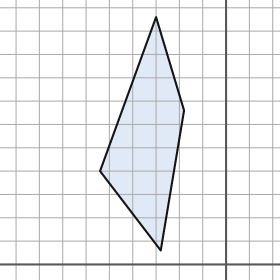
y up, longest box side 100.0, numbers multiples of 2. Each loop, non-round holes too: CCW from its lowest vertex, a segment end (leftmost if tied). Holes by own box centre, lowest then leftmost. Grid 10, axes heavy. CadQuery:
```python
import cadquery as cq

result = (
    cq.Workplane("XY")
    .moveTo(-28.0, 6.0)
    .lineTo(-18.0, 66.0)
    .lineTo(-30.0, 106.0)
    .lineTo(-54.0, 40.0)
    .close()
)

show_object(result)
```